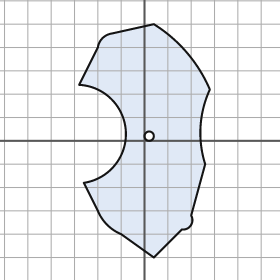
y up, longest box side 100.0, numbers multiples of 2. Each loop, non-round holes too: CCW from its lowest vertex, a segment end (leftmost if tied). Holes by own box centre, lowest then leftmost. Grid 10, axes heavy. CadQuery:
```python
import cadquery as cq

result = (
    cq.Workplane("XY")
    .moveTo(4.0, -50.0)
    .lineTo(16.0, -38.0)
    .threePointArc((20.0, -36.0), (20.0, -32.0))
    .lineTo(26.0, -10.0)
    .threePointArc((24.0, 6.0), (28.0, 22.0))
    .threePointArc((18.0, 38.0), (4.0, 50.0))
    .lineTo(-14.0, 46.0)
    .threePointArc((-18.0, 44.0), (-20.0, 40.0))
    .lineTo(-28.0, 24.0)
    .threePointArc((-8.0, 4.0), (-26.0, -18.0))
    .lineTo(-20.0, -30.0)
    .threePointArc((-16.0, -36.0), (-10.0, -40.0))
    .close()
    .moveTo(2.0, 2.0)
    .circle(2.0)
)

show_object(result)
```